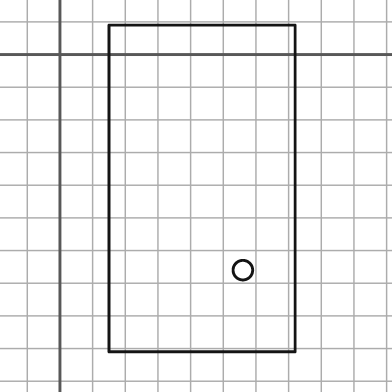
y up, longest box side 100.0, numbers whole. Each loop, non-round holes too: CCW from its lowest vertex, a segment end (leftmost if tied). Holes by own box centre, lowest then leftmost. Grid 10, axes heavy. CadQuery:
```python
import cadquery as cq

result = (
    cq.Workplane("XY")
    .moveTo(15.0, -91.0)
    .lineTo(72.0, -91.0)
    .lineTo(72.0, 9.0)
    .lineTo(15.0, 9.0)
    .close()
    .moveTo(56.0, -66.0)
    .circle(3.0)
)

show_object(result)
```